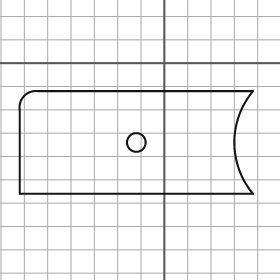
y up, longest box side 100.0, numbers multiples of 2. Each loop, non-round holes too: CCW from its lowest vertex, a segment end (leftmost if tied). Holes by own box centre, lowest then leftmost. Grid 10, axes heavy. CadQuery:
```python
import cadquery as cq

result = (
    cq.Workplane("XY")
    .moveTo(-62.0, -56.0)
    .lineTo(38.0, -56.0)
    .threePointArc((30.0, -34.0), (38.0, -12.0))
    .lineTo(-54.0, -12.0)
    .threePointArc((-60.0, -14.0), (-62.0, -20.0))
    .close()
    .moveTo(-12.0, -34.0)
    .circle(4.0)
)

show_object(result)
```